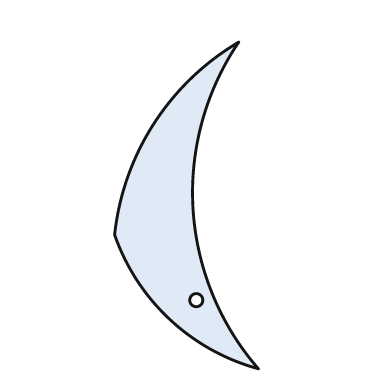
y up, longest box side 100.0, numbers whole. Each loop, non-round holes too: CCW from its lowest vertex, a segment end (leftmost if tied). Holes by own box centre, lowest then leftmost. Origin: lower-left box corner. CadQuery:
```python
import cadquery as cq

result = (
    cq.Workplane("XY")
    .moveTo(44.0, 0.0)
    .threePointArc((24.0, 49.0), (38.0, 100.0))
    .threePointArc((12.0, 75.0), (0.0, 41.0))
    .threePointArc((17.0, 15.0), (44.0, 0.0))
    .close()
    .moveTo(25.0, 21.0)
    .circle(2.0)
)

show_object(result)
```